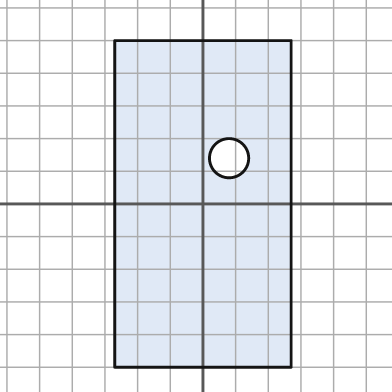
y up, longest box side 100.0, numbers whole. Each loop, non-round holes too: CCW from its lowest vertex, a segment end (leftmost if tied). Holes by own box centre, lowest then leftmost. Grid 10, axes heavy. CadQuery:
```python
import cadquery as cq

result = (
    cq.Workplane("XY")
    .moveTo(-27.0, -50.0)
    .lineTo(27.0, -50.0)
    .lineTo(27.0, 50.0)
    .lineTo(-27.0, 50.0)
    .close()
    .moveTo(8.0, 14.0)
    .circle(6.0)
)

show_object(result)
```